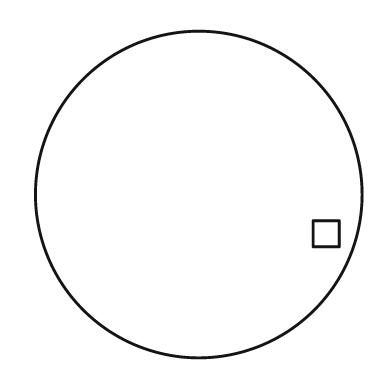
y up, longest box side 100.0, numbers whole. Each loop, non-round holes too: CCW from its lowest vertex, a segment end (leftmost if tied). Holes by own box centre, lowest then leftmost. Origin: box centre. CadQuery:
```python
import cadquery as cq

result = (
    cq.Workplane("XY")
    .moveTo(0.0, 0.0)
    .circle(50.0)
    .moveTo(35.0, -16.0)
    .lineTo(43.0, -16.0)
    .lineTo(43.0, -8.0)
    .lineTo(35.0, -8.0)
    .close()
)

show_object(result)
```